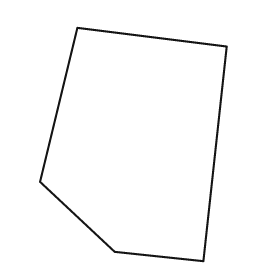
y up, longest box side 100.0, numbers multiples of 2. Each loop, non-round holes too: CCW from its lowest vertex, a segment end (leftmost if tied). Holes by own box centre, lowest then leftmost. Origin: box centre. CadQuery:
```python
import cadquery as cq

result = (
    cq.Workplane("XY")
    .moveTo(30.0, -50.0)
    .lineTo(40.0, 42.0)
    .lineTo(-24.0, 50.0)
    .lineTo(-40.0, -16.0)
    .lineTo(-8.0, -46.0)
    .close()
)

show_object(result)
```